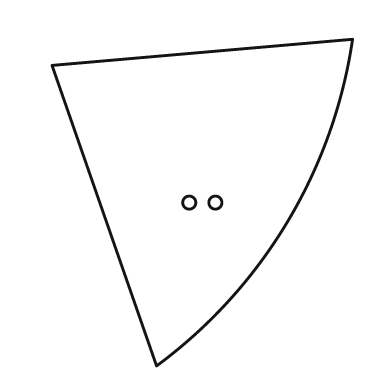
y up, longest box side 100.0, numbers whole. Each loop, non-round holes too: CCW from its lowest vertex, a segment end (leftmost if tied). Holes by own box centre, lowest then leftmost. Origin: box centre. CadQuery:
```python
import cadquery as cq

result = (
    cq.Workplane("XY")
    .moveTo(-14.0, -50.0)
    .threePointArc((26.0, -6.0), (46.0, 50.0))
    .lineTo(-46.0, 42.0)
    .close()
    .moveTo(-4.0, 0.0)
    .circle(2.0)
    .moveTo(4.0, 0.0)
    .circle(2.0)
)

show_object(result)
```